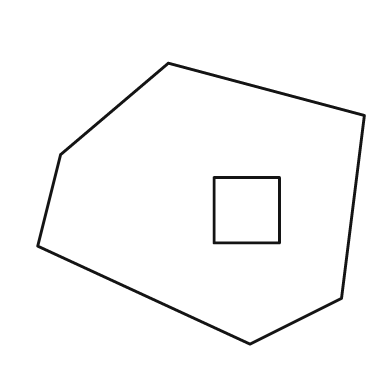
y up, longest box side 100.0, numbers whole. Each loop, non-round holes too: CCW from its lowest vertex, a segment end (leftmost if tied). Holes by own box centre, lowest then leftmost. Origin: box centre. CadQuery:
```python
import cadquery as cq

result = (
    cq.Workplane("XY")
    .moveTo(15.0, -43.0)
    .lineTo(43.0, -29.0)
    .lineTo(50.0, 27.0)
    .lineTo(-10.0, 43.0)
    .lineTo(-43.0, 15.0)
    .lineTo(-50.0, -13.0)
    .close()
    .moveTo(4.0, -12.0)
    .lineTo(24.0, -12.0)
    .lineTo(24.0, 8.0)
    .lineTo(4.0, 8.0)
    .close()
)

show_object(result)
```